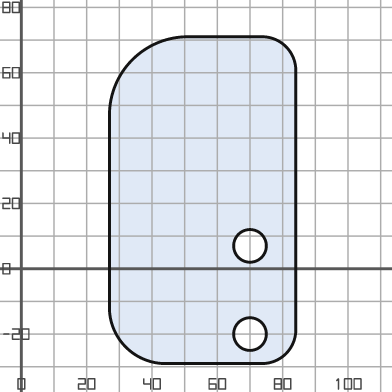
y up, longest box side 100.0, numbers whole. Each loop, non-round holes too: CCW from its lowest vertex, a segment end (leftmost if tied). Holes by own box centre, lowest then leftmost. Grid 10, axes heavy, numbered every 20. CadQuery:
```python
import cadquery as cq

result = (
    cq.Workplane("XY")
    .moveTo(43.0, -29.0)
    .lineTo(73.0, -29.0)
    .threePointArc((81.0, -26.0), (84.0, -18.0))
    .lineTo(84.0, 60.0)
    .threePointArc((81.0, 68.0), (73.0, 71.0))
    .lineTo(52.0, 71.0)
    .threePointArc((34.0, 64.0), (27.0, 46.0))
    .lineTo(27.0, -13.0)
    .threePointArc((32.0, -24.0), (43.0, -29.0))
    .close()
    .moveTo(70.0, -20.0)
    .circle(5.0)
    .moveTo(70.0, 7.0)
    .circle(5.0)
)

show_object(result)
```